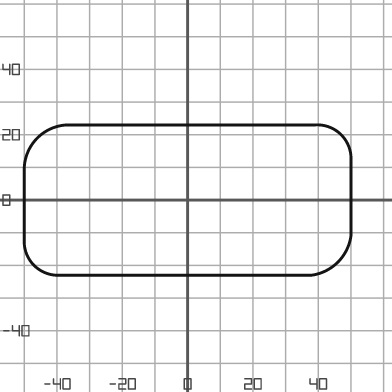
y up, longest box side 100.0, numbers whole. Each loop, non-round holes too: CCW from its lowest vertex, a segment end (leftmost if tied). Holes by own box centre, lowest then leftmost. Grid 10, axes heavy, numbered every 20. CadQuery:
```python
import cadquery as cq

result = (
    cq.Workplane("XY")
    .moveTo(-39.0, -23.0)
    .lineTo(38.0, -23.0)
    .threePointArc((46.0, -19.0), (50.0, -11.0))
    .lineTo(50.0, 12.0)
    .threePointArc((47.0, 20.0), (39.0, 23.0))
    .lineTo(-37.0, 23.0)
    .threePointArc((-46.0, 19.0), (-50.0, 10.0))
    .lineTo(-50.0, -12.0)
    .threePointArc((-47.0, -20.0), (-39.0, -23.0))
    .close()
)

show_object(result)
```